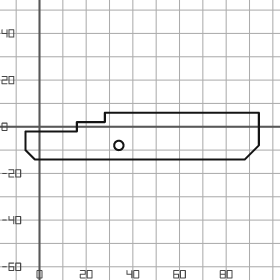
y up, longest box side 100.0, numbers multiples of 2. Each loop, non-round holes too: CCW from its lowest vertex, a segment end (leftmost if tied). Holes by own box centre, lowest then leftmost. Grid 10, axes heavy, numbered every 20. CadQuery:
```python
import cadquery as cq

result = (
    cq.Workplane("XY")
    .moveTo(-2.0, -14.0)
    .lineTo(88.0, -14.0)
    .lineTo(94.0, -8.0)
    .lineTo(94.0, 6.0)
    .lineTo(28.0, 6.0)
    .lineTo(28.0, 2.0)
    .lineTo(16.0, 2.0)
    .lineTo(16.0, -2.0)
    .lineTo(-6.0, -2.0)
    .lineTo(-6.0, -10.0)
    .close()
    .moveTo(34.0, -8.0)
    .circle(2.0)
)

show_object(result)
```